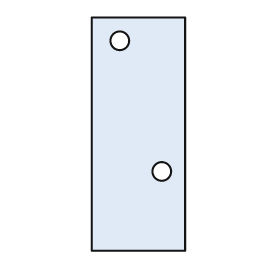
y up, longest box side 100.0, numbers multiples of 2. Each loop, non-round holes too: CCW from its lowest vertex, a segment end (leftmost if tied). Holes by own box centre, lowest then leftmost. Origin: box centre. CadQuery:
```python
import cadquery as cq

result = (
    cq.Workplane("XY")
    .moveTo(-20.0, -50.0)
    .lineTo(20.0, -50.0)
    .lineTo(20.0, 50.0)
    .lineTo(-20.0, 50.0)
    .close()
    .moveTo(10.0, -16.0)
    .circle(4.0)
    .moveTo(-8.0, 40.0)
    .circle(4.0)
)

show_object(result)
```